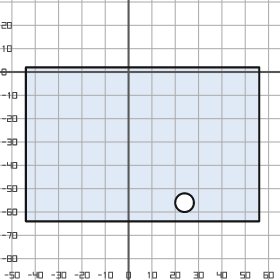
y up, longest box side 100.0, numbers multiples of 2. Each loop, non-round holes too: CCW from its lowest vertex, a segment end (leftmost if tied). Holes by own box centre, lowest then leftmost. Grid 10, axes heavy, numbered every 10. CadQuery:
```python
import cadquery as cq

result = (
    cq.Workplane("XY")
    .moveTo(-44.0, -64.0)
    .lineTo(56.0, -64.0)
    .lineTo(56.0, 2.0)
    .lineTo(-44.0, 2.0)
    .close()
    .moveTo(24.0, -56.0)
    .circle(4.0)
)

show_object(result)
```